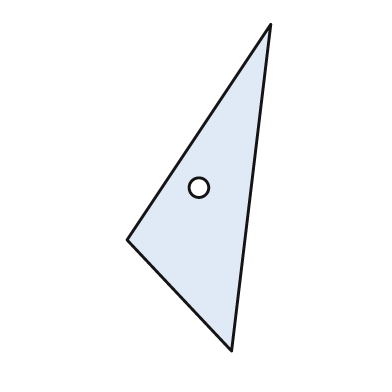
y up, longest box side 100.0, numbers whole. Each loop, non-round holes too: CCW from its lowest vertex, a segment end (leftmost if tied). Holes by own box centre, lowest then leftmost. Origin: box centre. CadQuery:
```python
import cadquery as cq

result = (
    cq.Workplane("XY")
    .moveTo(10.0, -50.0)
    .lineTo(22.0, 50.0)
    .lineTo(-22.0, -16.0)
    .close()
    .moveTo(0.0, 0.0)
    .circle(3.0)
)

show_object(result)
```